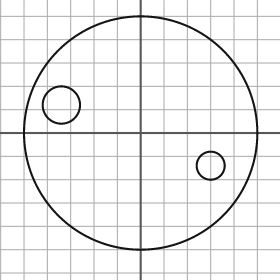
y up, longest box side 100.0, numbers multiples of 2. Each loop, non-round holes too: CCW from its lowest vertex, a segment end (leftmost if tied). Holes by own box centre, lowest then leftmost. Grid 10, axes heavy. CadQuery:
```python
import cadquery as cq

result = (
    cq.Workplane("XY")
    .moveTo(0.0, 0.0)
    .circle(50.0)
    .moveTo(30.0, -14.0)
    .circle(6.0)
    .moveTo(-34.0, 12.0)
    .circle(8.0)
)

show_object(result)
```